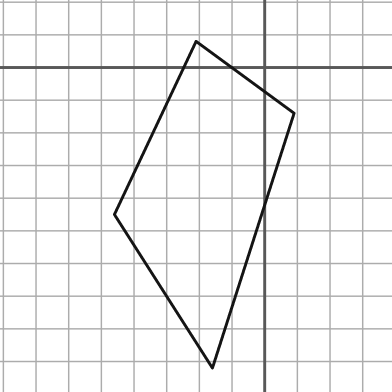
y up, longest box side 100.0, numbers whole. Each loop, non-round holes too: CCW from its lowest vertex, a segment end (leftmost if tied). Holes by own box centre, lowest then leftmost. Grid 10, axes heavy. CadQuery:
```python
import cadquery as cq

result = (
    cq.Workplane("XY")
    .moveTo(-16.0, -92.0)
    .lineTo(9.0, -14.0)
    .lineTo(-21.0, 8.0)
    .lineTo(-46.0, -45.0)
    .close()
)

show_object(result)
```